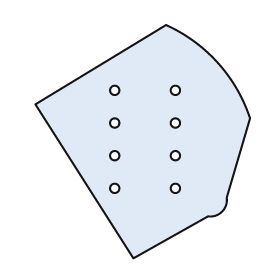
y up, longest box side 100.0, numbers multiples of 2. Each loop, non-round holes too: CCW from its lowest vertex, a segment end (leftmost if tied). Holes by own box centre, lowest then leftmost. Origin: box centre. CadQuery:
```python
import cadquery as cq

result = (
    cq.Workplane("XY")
    .moveTo(-4.0, -50.0)
    .lineTo(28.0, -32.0)
    .threePointArc((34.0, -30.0), (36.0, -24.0))
    .lineTo(46.0, 10.0)
    .threePointArc((32.0, 34.0), (10.0, 50.0))
    .lineTo(-46.0, 16.0)
    .close()
    .moveTo(-12.0, -20.0)
    .circle(2.0)
    .moveTo(14.0, -20.0)
    .circle(2.0)
    .moveTo(-12.0, -6.0)
    .circle(2.0)
    .moveTo(14.0, -6.0)
    .circle(2.0)
    .moveTo(-12.0, 8.0)
    .circle(2.0)
    .moveTo(14.0, 8.0)
    .circle(2.0)
    .moveTo(-12.0, 22.0)
    .circle(2.0)
    .moveTo(14.0, 22.0)
    .circle(2.0)
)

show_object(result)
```